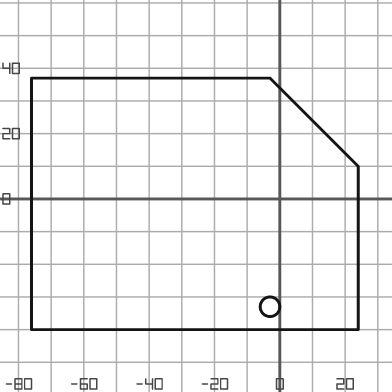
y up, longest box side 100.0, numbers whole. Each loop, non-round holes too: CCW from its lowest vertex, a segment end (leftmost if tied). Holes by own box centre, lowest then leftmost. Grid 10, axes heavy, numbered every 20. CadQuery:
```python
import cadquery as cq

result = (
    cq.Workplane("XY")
    .moveTo(-76.0, -40.0)
    .lineTo(24.0, -40.0)
    .lineTo(24.0, 10.0)
    .lineTo(-3.0, 37.0)
    .lineTo(-76.0, 37.0)
    .close()
    .moveTo(-3.0, -33.0)
    .circle(3.0)
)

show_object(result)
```